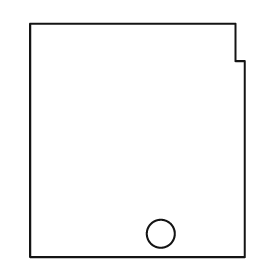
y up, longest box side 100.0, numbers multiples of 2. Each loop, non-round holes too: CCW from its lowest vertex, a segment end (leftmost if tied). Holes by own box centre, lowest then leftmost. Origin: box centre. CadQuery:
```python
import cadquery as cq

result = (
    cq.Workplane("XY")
    .moveTo(-46.0, -50.0)
    .lineTo(46.0, -50.0)
    .lineTo(46.0, 34.0)
    .lineTo(42.0, 34.0)
    .lineTo(42.0, 50.0)
    .lineTo(-46.0, 50.0)
    .close()
    .moveTo(10.0, -40.0)
    .circle(6.0)
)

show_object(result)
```